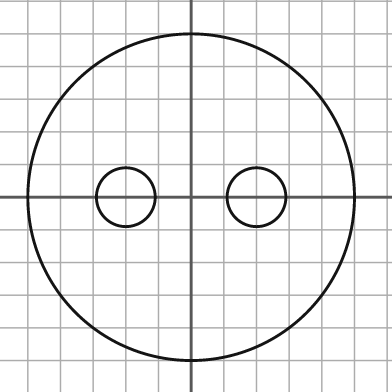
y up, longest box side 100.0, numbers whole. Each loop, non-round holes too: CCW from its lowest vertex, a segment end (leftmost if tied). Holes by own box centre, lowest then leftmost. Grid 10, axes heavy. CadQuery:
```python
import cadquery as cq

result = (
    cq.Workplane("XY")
    .moveTo(0.0, 0.0)
    .circle(50.0)
    .moveTo(-20.0, 0.0)
    .circle(9.0)
    .moveTo(20.0, 0.0)
    .circle(9.0)
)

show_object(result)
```